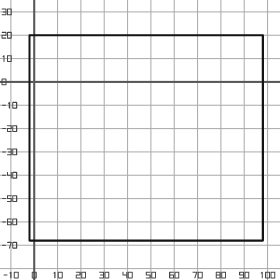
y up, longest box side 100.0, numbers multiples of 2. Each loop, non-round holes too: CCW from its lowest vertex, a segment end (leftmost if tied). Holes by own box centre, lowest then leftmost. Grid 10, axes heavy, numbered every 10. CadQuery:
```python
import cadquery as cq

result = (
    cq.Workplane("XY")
    .moveTo(-2.0, -68.0)
    .lineTo(98.0, -68.0)
    .lineTo(98.0, 20.0)
    .lineTo(-2.0, 20.0)
    .close()
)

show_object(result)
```